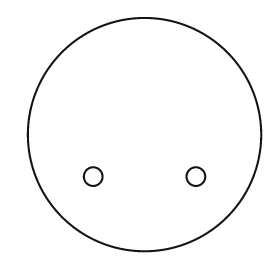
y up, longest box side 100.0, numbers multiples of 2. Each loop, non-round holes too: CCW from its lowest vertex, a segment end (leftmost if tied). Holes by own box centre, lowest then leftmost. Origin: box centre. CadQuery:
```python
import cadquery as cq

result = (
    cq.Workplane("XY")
    .moveTo(0.0, 0.0)
    .circle(50.0)
    .moveTo(-22.0, -18.0)
    .circle(4.0)
    .moveTo(22.0, -18.0)
    .circle(4.0)
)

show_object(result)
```